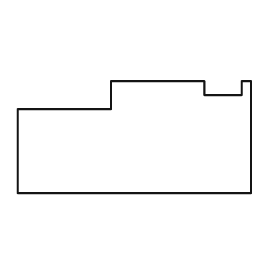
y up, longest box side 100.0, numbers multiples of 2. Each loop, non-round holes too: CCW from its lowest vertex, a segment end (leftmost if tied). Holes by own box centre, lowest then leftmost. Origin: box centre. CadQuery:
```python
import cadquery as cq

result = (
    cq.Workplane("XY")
    .moveTo(-50.0, -24.0)
    .lineTo(50.0, -24.0)
    .lineTo(50.0, 24.0)
    .lineTo(46.0, 24.0)
    .lineTo(46.0, 18.0)
    .lineTo(30.0, 18.0)
    .lineTo(30.0, 24.0)
    .lineTo(-10.0, 24.0)
    .lineTo(-10.0, 12.0)
    .lineTo(-50.0, 12.0)
    .close()
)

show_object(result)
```